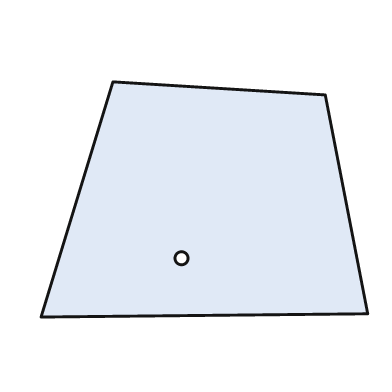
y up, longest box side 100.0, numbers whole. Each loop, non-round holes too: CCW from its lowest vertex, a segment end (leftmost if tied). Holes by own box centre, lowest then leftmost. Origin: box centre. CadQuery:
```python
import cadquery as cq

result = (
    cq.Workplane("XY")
    .moveTo(-50.0, -36.0)
    .lineTo(50.0, -35.0)
    .lineTo(37.0, 32.0)
    .lineTo(-28.0, 36.0)
    .close()
    .moveTo(-7.0, -18.0)
    .circle(2.0)
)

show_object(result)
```